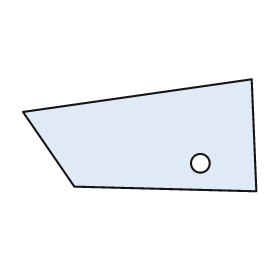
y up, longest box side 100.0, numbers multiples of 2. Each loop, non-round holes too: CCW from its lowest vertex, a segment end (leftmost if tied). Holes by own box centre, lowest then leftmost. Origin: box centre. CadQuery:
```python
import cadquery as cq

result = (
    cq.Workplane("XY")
    .moveTo(50.0, -24.0)
    .lineTo(48.0, 24.0)
    .lineTo(-50.0, 10.0)
    .lineTo(-28.0, -22.0)
    .close()
    .moveTo(26.0, -12.0)
    .circle(4.0)
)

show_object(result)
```